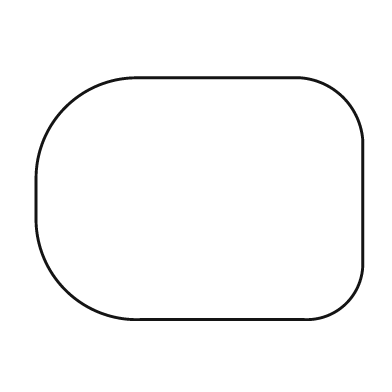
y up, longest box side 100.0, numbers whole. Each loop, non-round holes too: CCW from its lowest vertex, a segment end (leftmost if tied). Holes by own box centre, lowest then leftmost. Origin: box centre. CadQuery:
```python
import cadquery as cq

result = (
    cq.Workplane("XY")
    .moveTo(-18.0, -37.0)
    .lineTo(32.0, -37.0)
    .threePointArc((45.0, -32.0), (50.0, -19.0))
    .lineTo(50.0, 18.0)
    .threePointArc((44.0, 31.0), (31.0, 37.0))
    .lineTo(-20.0, 37.0)
    .threePointArc((-41.0, 28.0), (-50.0, 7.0))
    .lineTo(-50.0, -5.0)
    .threePointArc((-41.0, -28.0), (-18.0, -37.0))
    .close()
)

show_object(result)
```